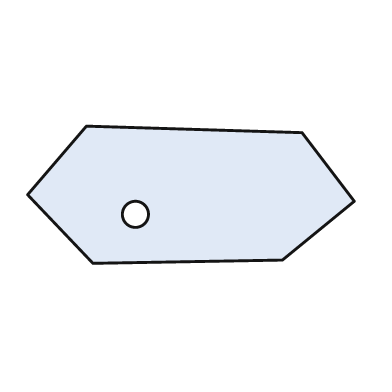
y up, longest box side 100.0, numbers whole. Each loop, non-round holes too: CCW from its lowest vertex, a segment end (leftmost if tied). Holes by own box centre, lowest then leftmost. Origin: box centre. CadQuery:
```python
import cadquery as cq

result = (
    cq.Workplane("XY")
    .moveTo(-30.0, -21.0)
    .lineTo(28.0, -20.0)
    .lineTo(50.0, -2.0)
    .lineTo(34.0, 19.0)
    .lineTo(-32.0, 21.0)
    .lineTo(-50.0, 0.0)
    .close()
    .moveTo(-17.0, -6.0)
    .circle(4.0)
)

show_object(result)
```